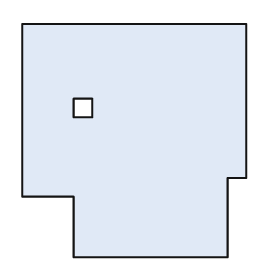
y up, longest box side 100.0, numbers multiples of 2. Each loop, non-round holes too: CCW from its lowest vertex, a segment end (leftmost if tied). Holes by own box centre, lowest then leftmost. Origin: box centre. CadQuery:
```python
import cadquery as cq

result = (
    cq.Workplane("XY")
    .moveTo(-26.0, -50.0)
    .lineTo(40.0, -50.0)
    .lineTo(40.0, -16.0)
    .lineTo(48.0, -16.0)
    .lineTo(48.0, 50.0)
    .lineTo(-48.0, 50.0)
    .lineTo(-48.0, -24.0)
    .lineTo(-26.0, -24.0)
    .close()
    .moveTo(-26.0, 10.0)
    .lineTo(-18.0, 10.0)
    .lineTo(-18.0, 18.0)
    .lineTo(-26.0, 18.0)
    .close()
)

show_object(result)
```